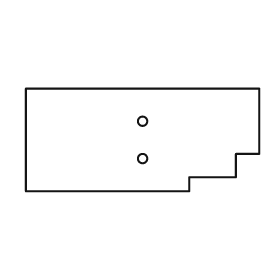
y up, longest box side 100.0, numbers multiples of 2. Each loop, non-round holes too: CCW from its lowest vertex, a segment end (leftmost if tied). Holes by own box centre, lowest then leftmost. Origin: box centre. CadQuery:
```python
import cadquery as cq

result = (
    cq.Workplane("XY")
    .moveTo(-50.0, -22.0)
    .lineTo(20.0, -22.0)
    .lineTo(20.0, -16.0)
    .lineTo(40.0, -16.0)
    .lineTo(40.0, -6.0)
    .lineTo(50.0, -6.0)
    .lineTo(50.0, 22.0)
    .lineTo(-50.0, 22.0)
    .close()
    .moveTo(0.0, -8.0)
    .circle(2.0)
    .moveTo(0.0, 8.0)
    .circle(2.0)
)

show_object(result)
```